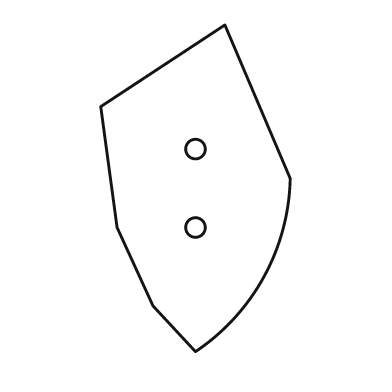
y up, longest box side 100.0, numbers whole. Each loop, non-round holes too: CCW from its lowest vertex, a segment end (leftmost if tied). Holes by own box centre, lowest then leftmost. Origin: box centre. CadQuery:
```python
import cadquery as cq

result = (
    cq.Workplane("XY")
    .moveTo(0.0, -50.0)
    .threePointArc((21.0, -27.0), (29.0, 3.0))
    .lineTo(9.0, 50.0)
    .lineTo(-29.0, 25.0)
    .lineTo(-24.0, -12.0)
    .lineTo(-13.0, -36.0)
    .close()
    .moveTo(0.0, -12.0)
    .circle(3.0)
    .moveTo(0.0, 12.0)
    .circle(3.0)
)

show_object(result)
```